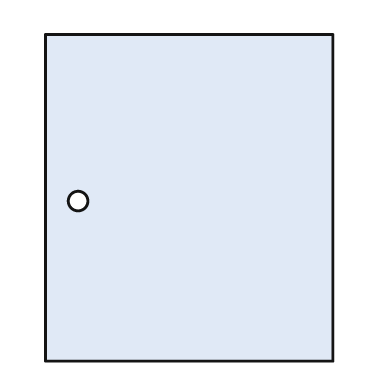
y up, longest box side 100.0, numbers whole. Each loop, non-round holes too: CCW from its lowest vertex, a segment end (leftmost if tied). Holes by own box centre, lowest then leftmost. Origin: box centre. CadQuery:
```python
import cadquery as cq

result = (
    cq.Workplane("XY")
    .moveTo(-44.0, -50.0)
    .lineTo(44.0, -50.0)
    .lineTo(44.0, 50.0)
    .lineTo(-44.0, 50.0)
    .close()
    .moveTo(-34.0, -1.0)
    .circle(3.0)
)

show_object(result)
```